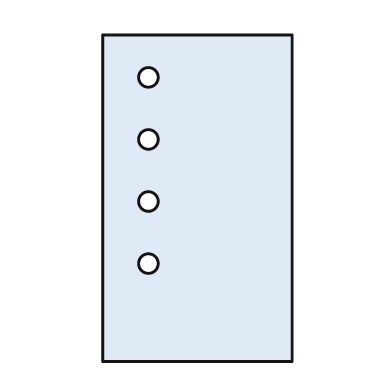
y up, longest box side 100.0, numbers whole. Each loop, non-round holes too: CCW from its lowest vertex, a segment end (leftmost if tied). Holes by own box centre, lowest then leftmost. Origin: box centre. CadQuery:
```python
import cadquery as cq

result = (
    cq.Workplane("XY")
    .moveTo(-29.0, -50.0)
    .lineTo(29.0, -50.0)
    .lineTo(29.0, 50.0)
    .lineTo(-29.0, 50.0)
    .close()
    .moveTo(-15.0, -20.0)
    .circle(3.0)
    .moveTo(-15.0, -1.0)
    .circle(3.0)
    .moveTo(-15.0, 18.0)
    .circle(3.0)
    .moveTo(-15.0, 37.0)
    .circle(3.0)
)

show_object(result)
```